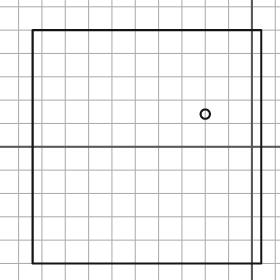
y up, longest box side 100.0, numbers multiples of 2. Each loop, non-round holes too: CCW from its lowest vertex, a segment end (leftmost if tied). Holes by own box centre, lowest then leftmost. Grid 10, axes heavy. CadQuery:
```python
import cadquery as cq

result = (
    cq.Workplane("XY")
    .moveTo(-94.0, -50.0)
    .lineTo(4.0, -50.0)
    .lineTo(4.0, 50.0)
    .lineTo(-94.0, 50.0)
    .close()
    .moveTo(-20.0, 14.0)
    .circle(2.0)
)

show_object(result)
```